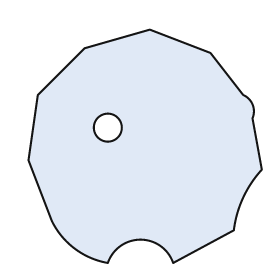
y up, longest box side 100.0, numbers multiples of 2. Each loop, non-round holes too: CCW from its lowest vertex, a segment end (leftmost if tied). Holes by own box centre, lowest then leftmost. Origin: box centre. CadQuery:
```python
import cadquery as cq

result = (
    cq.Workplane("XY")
    .moveTo(-16.0, -50.0)
    .threePointArc((-2.0, -40.0), (12.0, -50.0))
    .lineTo(38.0, -36.0)
    .threePointArc((42.0, -22.0), (50.0, -10.0))
    .lineTo(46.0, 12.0)
    .threePointArc((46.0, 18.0), (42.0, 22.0))
    .lineTo(28.0, 40.0)
    .lineTo(2.0, 50.0)
    .lineTo(-26.0, 42.0)
    .lineTo(-46.0, 22.0)
    .lineTo(-50.0, -6.0)
    .lineTo(-40.0, -32.0)
    .threePointArc((-30.0, -44.0), (-16.0, -50.0))
    .close()
    .moveTo(-16.0, 8.0)
    .circle(6.0)
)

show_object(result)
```